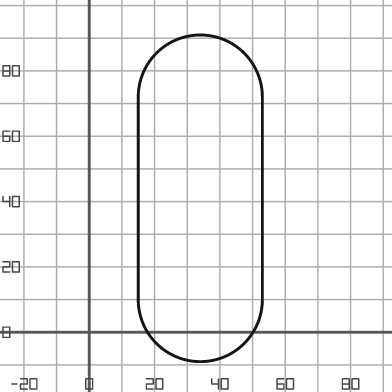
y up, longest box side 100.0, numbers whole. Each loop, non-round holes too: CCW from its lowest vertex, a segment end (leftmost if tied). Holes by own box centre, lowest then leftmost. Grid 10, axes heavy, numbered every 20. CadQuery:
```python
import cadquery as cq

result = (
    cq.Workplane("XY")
    .moveTo(15.0, 10.0)
    .threePointArc((34.0, -9.0), (53.0, 10.0))
    .lineTo(53.0, 72.0)
    .threePointArc((34.0, 91.0), (15.0, 72.0))
    .close()
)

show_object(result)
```